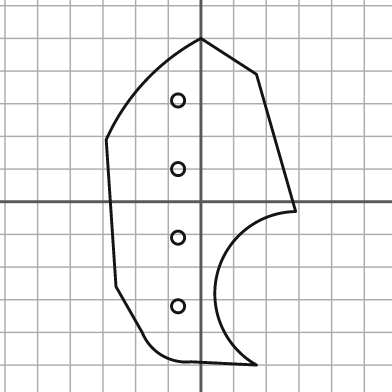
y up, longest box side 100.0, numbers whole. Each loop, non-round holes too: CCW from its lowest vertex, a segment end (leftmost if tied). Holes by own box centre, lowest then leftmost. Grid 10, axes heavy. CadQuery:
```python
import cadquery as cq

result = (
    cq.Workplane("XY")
    .moveTo(17.0, -50.0)
    .threePointArc((5.0, -22.0), (29.0, -3.0))
    .lineTo(17.0, 39.0)
    .lineTo(0.0, 50.0)
    .threePointArc((-17.0, 37.0), (-29.0, 19.0))
    .lineTo(-26.0, -26.0)
    .lineTo(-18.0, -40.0)
    .threePointArc((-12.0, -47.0), (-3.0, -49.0))
    .close()
    .moveTo(-7.0, -32.0)
    .circle(2.0)
    .moveTo(-7.0, -11.0)
    .circle(2.0)
    .moveTo(-7.0, 10.0)
    .circle(2.0)
    .moveTo(-7.0, 31.0)
    .circle(2.0)
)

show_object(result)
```